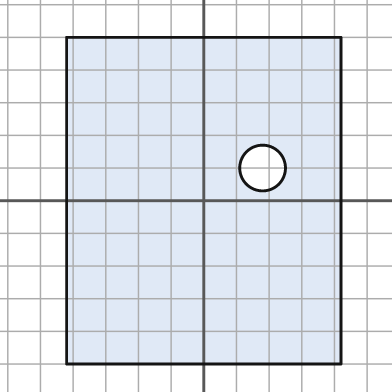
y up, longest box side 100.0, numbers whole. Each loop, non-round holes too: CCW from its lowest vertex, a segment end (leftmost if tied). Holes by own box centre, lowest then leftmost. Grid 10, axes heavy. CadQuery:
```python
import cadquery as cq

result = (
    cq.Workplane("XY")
    .moveTo(-42.0, -50.0)
    .lineTo(42.0, -50.0)
    .lineTo(42.0, 50.0)
    .lineTo(-42.0, 50.0)
    .close()
    .moveTo(18.0, 10.0)
    .circle(7.0)
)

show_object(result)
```